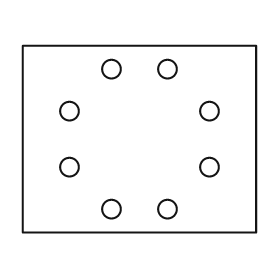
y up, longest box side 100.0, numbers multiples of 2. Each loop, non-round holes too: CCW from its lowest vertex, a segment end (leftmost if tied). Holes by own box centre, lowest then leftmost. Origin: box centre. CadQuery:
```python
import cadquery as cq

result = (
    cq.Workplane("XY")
    .moveTo(-50.0, -40.0)
    .lineTo(50.0, -40.0)
    .lineTo(50.0, 40.0)
    .lineTo(-50.0, 40.0)
    .close()
    .moveTo(-12.0, -30.0)
    .circle(4.0)
    .moveTo(12.0, -30.0)
    .circle(4.0)
    .moveTo(-30.0, -12.0)
    .circle(4.0)
    .moveTo(30.0, -12.0)
    .circle(4.0)
    .moveTo(-30.0, 12.0)
    .circle(4.0)
    .moveTo(30.0, 12.0)
    .circle(4.0)
    .moveTo(-12.0, 30.0)
    .circle(4.0)
    .moveTo(12.0, 30.0)
    .circle(4.0)
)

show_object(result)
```